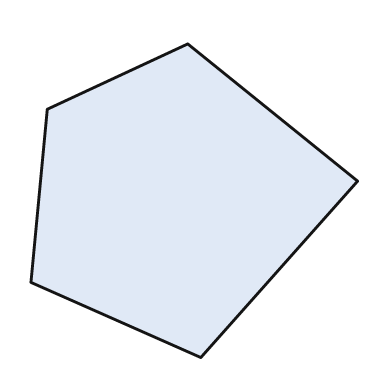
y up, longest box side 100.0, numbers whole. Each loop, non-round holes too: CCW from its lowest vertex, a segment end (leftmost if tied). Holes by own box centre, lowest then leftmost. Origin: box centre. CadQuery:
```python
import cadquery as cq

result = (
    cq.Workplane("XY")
    .moveTo(2.0, -48.0)
    .lineTo(50.0, 6.0)
    .lineTo(-2.0, 48.0)
    .lineTo(-45.0, 28.0)
    .lineTo(-50.0, -25.0)
    .close()
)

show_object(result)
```